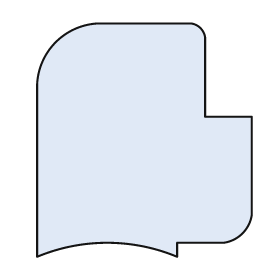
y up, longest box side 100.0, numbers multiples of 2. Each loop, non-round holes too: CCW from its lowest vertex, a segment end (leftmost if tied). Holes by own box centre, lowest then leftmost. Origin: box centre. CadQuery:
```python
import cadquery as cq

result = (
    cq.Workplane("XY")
    .moveTo(-46.0, -50.0)
    .threePointArc((-16.0, -44.0), (14.0, -50.0))
    .lineTo(14.0, -44.0)
    .lineTo(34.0, -44.0)
    .threePointArc((42.0, -40.0), (46.0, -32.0))
    .lineTo(46.0, 10.0)
    .lineTo(26.0, 10.0)
    .lineTo(26.0, 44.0)
    .threePointArc((24.0, 48.0), (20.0, 50.0))
    .lineTo(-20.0, 50.0)
    .threePointArc((-38.0, 42.0), (-46.0, 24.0))
    .close()
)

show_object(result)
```